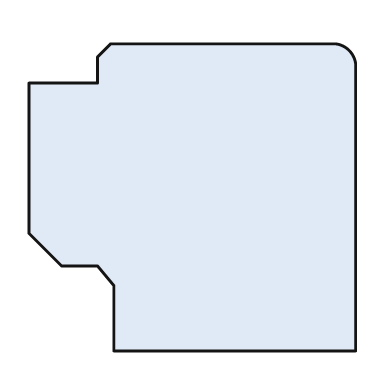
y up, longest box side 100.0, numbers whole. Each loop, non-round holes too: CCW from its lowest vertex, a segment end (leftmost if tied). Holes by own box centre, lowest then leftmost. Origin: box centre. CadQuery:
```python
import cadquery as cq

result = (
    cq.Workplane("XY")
    .moveTo(-24.0, -47.0)
    .lineTo(50.0, -47.0)
    .lineTo(50.0, 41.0)
    .threePointArc((48.0, 45.0), (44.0, 47.0))
    .lineTo(-25.0, 47.0)
    .lineTo(-29.0, 43.0)
    .lineTo(-29.0, 35.0)
    .lineTo(-50.0, 35.0)
    .lineTo(-50.0, -11.0)
    .lineTo(-40.0, -21.0)
    .lineTo(-29.0, -21.0)
    .lineTo(-24.0, -27.0)
    .close()
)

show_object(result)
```